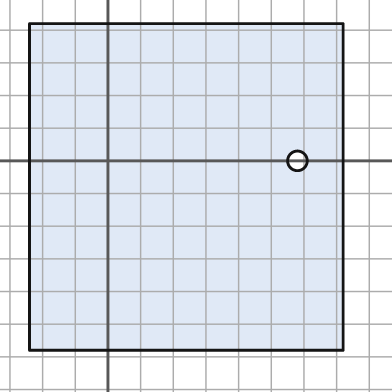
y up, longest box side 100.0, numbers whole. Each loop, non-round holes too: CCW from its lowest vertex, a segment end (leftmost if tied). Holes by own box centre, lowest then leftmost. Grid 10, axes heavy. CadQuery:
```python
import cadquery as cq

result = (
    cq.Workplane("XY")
    .moveTo(-24.0, -58.0)
    .lineTo(72.0, -58.0)
    .lineTo(72.0, 42.0)
    .lineTo(-24.0, 42.0)
    .close()
    .moveTo(58.0, 0.0)
    .circle(3.0)
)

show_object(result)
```